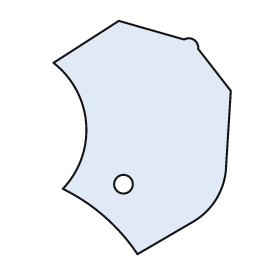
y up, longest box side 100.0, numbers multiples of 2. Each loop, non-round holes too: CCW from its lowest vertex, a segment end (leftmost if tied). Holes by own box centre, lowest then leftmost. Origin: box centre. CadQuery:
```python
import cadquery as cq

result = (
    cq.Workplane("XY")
    .moveTo(-2.0, -50.0)
    .lineTo(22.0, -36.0)
    .threePointArc((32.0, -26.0), (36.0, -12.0))
    .lineTo(38.0, 20.0)
    .lineTo(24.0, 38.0)
    .threePointArc((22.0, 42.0), (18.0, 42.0))
    .lineTo(-10.0, 50.0)
    .lineTo(-38.0, 32.0)
    .threePointArc((-24.0, 6.0), (-34.0, -22.0))
    .threePointArc((-16.0, -34.0), (-2.0, -50.0))
    .close()
    .moveTo(-8.0, -20.0)
    .circle(4.0)
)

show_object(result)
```